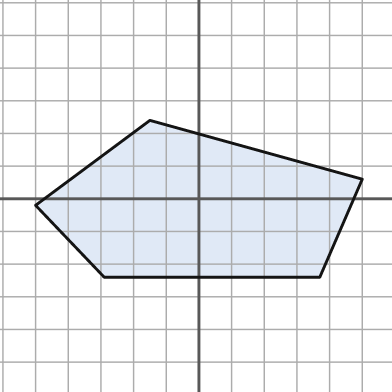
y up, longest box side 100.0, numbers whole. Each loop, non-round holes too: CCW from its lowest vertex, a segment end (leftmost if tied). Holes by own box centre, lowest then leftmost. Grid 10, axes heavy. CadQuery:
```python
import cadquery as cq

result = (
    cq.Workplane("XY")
    .moveTo(-29.0, -24.0)
    .lineTo(37.0, -24.0)
    .lineTo(50.0, 6.0)
    .lineTo(-15.0, 24.0)
    .lineTo(-50.0, -2.0)
    .close()
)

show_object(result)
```